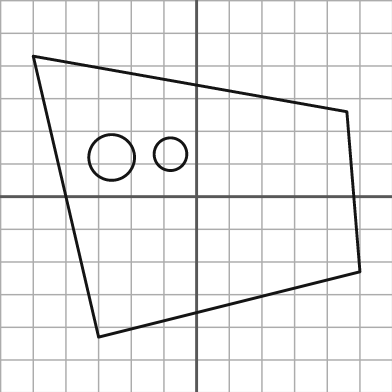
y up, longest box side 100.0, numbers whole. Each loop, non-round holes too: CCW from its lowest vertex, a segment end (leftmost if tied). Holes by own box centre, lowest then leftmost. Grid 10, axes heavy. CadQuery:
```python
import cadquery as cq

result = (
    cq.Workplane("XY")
    .moveTo(-30.0, -43.0)
    .lineTo(50.0, -23.0)
    .lineTo(46.0, 26.0)
    .lineTo(-50.0, 43.0)
    .close()
    .moveTo(-26.0, 12.0)
    .circle(7.0)
    .moveTo(-8.0, 13.0)
    .circle(5.0)
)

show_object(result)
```